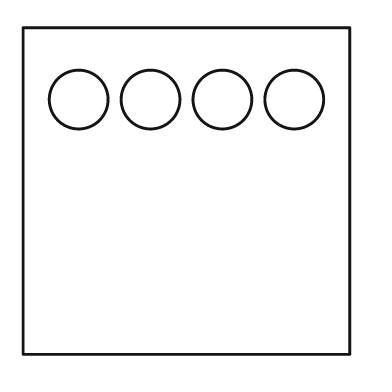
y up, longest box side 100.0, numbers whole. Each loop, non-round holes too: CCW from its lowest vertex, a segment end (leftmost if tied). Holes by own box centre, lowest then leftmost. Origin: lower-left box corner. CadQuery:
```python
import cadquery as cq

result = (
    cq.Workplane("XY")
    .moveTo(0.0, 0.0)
    .lineTo(100.0, 0.0)
    .lineTo(100.0, 100.0)
    .lineTo(0.0, 100.0)
    .close()
    .moveTo(17.0, 78.0)
    .circle(9.0)
    .moveTo(39.0, 78.0)
    .circle(9.0)
    .moveTo(61.0, 78.0)
    .circle(9.0)
    .moveTo(83.0, 78.0)
    .circle(9.0)
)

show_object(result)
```